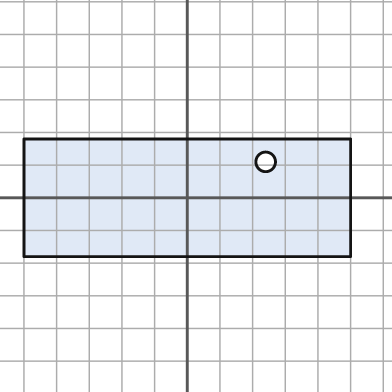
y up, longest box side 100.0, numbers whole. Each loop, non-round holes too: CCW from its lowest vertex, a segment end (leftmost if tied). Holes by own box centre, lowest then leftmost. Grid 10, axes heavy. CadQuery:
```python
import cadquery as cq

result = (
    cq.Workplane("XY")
    .moveTo(-50.0, -18.0)
    .lineTo(50.0, -18.0)
    .lineTo(50.0, 18.0)
    .lineTo(-50.0, 18.0)
    .close()
    .moveTo(24.0, 11.0)
    .circle(3.0)
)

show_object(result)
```